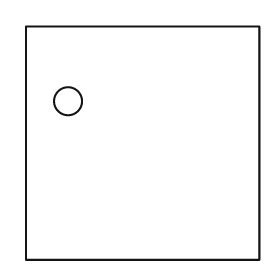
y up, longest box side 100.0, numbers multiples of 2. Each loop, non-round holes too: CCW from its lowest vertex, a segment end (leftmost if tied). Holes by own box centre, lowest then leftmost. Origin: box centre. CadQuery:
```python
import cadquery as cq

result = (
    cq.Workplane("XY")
    .moveTo(-50.0, -50.0)
    .lineTo(50.0, -50.0)
    .lineTo(50.0, 50.0)
    .lineTo(-50.0, 50.0)
    .close()
    .moveTo(-32.0, 18.0)
    .circle(6.0)
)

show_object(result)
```